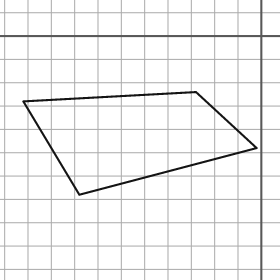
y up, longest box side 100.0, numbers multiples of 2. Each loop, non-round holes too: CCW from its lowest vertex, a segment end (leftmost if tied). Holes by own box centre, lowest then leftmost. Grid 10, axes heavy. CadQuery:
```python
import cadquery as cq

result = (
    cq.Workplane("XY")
    .moveTo(-78.0, -68.0)
    .lineTo(-2.0, -48.0)
    .lineTo(-28.0, -24.0)
    .lineTo(-102.0, -28.0)
    .close()
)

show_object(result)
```